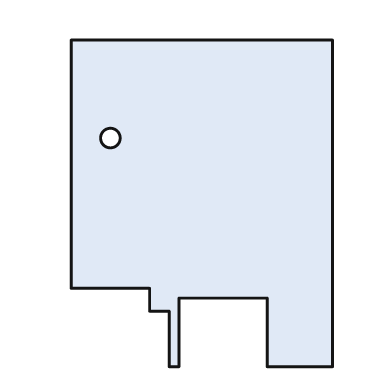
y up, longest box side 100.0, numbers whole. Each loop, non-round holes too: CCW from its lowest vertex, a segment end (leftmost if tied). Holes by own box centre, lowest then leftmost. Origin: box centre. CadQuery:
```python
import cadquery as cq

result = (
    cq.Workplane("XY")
    .moveTo(-10.0, -50.0)
    .lineTo(-7.0, -50.0)
    .lineTo(-7.0, -29.0)
    .lineTo(20.0, -29.0)
    .lineTo(20.0, -50.0)
    .lineTo(40.0, -50.0)
    .lineTo(40.0, 50.0)
    .lineTo(-40.0, 50.0)
    .lineTo(-40.0, -26.0)
    .lineTo(-16.0, -26.0)
    .lineTo(-16.0, -33.0)
    .lineTo(-10.0, -33.0)
    .close()
    .moveTo(-28.0, 20.0)
    .circle(3.0)
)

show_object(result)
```